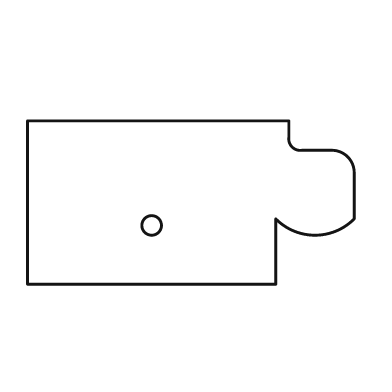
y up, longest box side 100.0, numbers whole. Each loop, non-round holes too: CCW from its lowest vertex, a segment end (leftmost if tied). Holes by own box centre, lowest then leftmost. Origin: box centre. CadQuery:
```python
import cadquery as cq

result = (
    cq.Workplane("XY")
    .moveTo(-50.0, -25.0)
    .lineTo(26.0, -25.0)
    .lineTo(26.0, -5.0)
    .threePointArc((38.0, -10.0), (50.0, -5.0))
    .lineTo(50.0, 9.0)
    .threePointArc((48.0, 14.0), (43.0, 16.0))
    .lineTo(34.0, 16.0)
    .threePointArc((31.0, 17.0), (30.0, 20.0))
    .lineTo(30.0, 25.0)
    .lineTo(-50.0, 25.0)
    .close()
    .moveTo(-12.0, -7.0)
    .circle(3.0)
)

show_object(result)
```